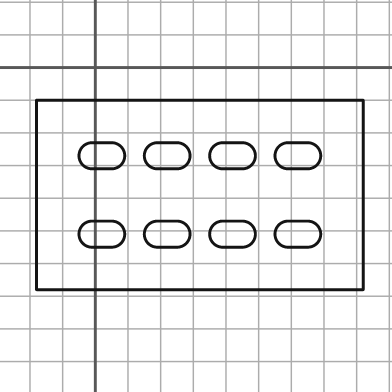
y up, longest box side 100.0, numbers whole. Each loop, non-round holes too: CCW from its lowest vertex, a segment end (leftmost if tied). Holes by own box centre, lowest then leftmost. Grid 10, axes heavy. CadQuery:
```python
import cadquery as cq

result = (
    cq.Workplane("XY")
    .moveTo(-18.0, -68.0)
    .lineTo(82.0, -68.0)
    .lineTo(82.0, -10.0)
    .lineTo(-18.0, -10.0)
    .close()
    .moveTo(-1.0, -55.0)
    .lineTo(5.0, -55.0)
    .threePointArc((9.0, -51.0), (5.0, -47.0))
    .lineTo(-1.0, -47.0)
    .threePointArc((-5.0, -51.0), (-1.0, -55.0))
    .close()
    .moveTo(19.0, -55.0)
    .lineTo(25.0, -55.0)
    .threePointArc((29.0, -51.0), (25.0, -47.0))
    .lineTo(19.0, -47.0)
    .threePointArc((15.0, -51.0), (19.0, -55.0))
    .close()
    .moveTo(39.0, -55.0)
    .lineTo(45.0, -55.0)
    .threePointArc((49.0, -51.0), (45.0, -47.0))
    .lineTo(39.0, -47.0)
    .threePointArc((35.0, -51.0), (39.0, -55.0))
    .close()
    .moveTo(59.0, -55.0)
    .lineTo(65.0, -55.0)
    .threePointArc((69.0, -51.0), (65.0, -47.0))
    .lineTo(59.0, -47.0)
    .threePointArc((55.0, -51.0), (59.0, -55.0))
    .close()
    .moveTo(-1.0, -31.0)
    .lineTo(5.0, -31.0)
    .threePointArc((9.0, -27.0), (5.0, -23.0))
    .lineTo(-1.0, -23.0)
    .threePointArc((-5.0, -27.0), (-1.0, -31.0))
    .close()
    .moveTo(19.0, -31.0)
    .lineTo(25.0, -31.0)
    .threePointArc((29.0, -27.0), (25.0, -23.0))
    .lineTo(19.0, -23.0)
    .threePointArc((15.0, -27.0), (19.0, -31.0))
    .close()
    .moveTo(39.0, -31.0)
    .lineTo(45.0, -31.0)
    .threePointArc((49.0, -27.0), (45.0, -23.0))
    .lineTo(39.0, -23.0)
    .threePointArc((35.0, -27.0), (39.0, -31.0))
    .close()
    .moveTo(59.0, -31.0)
    .lineTo(65.0, -31.0)
    .threePointArc((69.0, -27.0), (65.0, -23.0))
    .lineTo(59.0, -23.0)
    .threePointArc((55.0, -27.0), (59.0, -31.0))
    .close()
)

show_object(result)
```